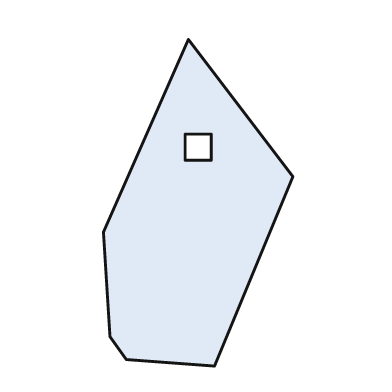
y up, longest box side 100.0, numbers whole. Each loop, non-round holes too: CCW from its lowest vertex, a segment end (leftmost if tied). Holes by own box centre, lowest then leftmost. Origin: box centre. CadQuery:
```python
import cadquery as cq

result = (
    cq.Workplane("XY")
    .moveTo(5.0, -50.0)
    .lineTo(29.0, 8.0)
    .lineTo(-3.0, 50.0)
    .lineTo(-29.0, -9.0)
    .lineTo(-27.0, -41.0)
    .lineTo(-22.0, -48.0)
    .close()
    .moveTo(-4.0, 13.0)
    .lineTo(4.0, 13.0)
    .lineTo(4.0, 21.0)
    .lineTo(-4.0, 21.0)
    .close()
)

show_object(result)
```